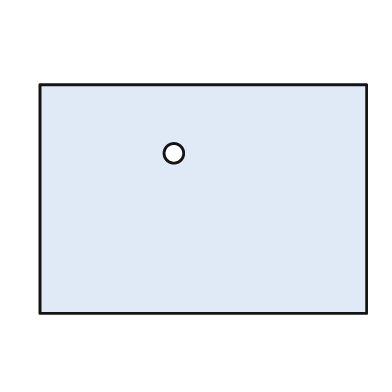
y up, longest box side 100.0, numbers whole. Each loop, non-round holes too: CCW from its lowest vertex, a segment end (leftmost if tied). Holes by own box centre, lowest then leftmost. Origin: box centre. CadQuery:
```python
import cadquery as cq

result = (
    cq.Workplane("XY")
    .moveTo(-50.0, -35.0)
    .lineTo(50.0, -35.0)
    .lineTo(50.0, 35.0)
    .lineTo(-50.0, 35.0)
    .close()
    .moveTo(-9.0, 14.0)
    .circle(3.0)
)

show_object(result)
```